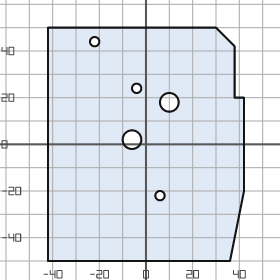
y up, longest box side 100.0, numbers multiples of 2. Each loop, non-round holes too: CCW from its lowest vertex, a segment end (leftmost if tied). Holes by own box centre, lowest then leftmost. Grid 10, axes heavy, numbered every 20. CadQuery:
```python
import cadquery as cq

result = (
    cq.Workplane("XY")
    .moveTo(-42.0, -50.0)
    .lineTo(36.0, -50.0)
    .lineTo(42.0, -20.0)
    .lineTo(42.0, 20.0)
    .lineTo(38.0, 20.0)
    .lineTo(38.0, 42.0)
    .lineTo(30.0, 50.0)
    .lineTo(-42.0, 50.0)
    .close()
    .moveTo(6.0, -22.0)
    .circle(2.0)
    .moveTo(-6.0, 2.0)
    .circle(4.0)
    .moveTo(10.0, 18.0)
    .circle(4.0)
    .moveTo(-4.0, 24.0)
    .circle(2.0)
    .moveTo(-22.0, 44.0)
    .circle(2.0)
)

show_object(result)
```